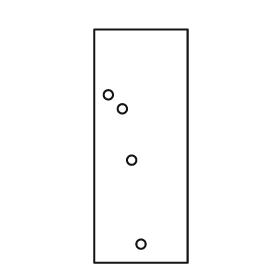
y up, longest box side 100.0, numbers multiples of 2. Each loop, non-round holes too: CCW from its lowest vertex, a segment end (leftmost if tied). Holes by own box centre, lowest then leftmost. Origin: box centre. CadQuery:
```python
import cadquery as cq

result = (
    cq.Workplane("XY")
    .moveTo(-20.0, -50.0)
    .lineTo(20.0, -50.0)
    .lineTo(20.0, 50.0)
    .lineTo(-20.0, 50.0)
    .close()
    .moveTo(0.0, -42.0)
    .circle(2.0)
    .moveTo(-4.0, -6.0)
    .circle(2.0)
    .moveTo(-8.0, 16.0)
    .circle(2.0)
    .moveTo(-14.0, 22.0)
    .circle(2.0)
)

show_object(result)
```